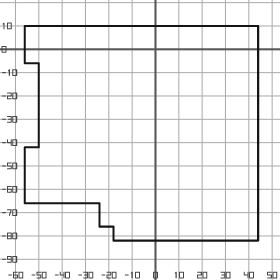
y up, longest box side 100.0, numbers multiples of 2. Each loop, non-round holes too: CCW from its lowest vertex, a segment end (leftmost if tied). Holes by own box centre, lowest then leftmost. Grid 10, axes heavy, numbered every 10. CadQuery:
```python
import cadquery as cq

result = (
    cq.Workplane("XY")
    .moveTo(-18.0, -82.0)
    .lineTo(44.0, -82.0)
    .lineTo(44.0, 10.0)
    .lineTo(-56.0, 10.0)
    .lineTo(-56.0, -6.0)
    .lineTo(-50.0, -6.0)
    .lineTo(-50.0, -42.0)
    .lineTo(-56.0, -42.0)
    .lineTo(-56.0, -66.0)
    .lineTo(-24.0, -66.0)
    .lineTo(-24.0, -76.0)
    .lineTo(-18.0, -76.0)
    .close()
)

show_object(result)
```